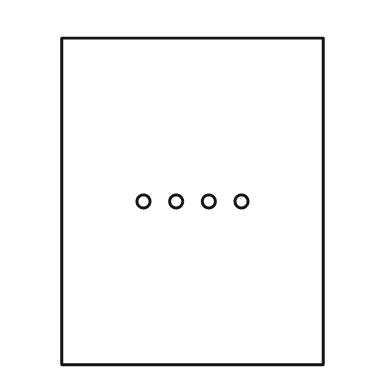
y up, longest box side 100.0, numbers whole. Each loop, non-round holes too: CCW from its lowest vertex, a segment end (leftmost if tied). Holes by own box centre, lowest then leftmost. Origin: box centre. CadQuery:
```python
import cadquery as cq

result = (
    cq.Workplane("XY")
    .moveTo(-40.0, -50.0)
    .lineTo(40.0, -50.0)
    .lineTo(40.0, 50.0)
    .lineTo(-40.0, 50.0)
    .close()
    .moveTo(-15.0, 0.0)
    .circle(2.0)
    .moveTo(-5.0, 0.0)
    .circle(2.0)
    .moveTo(5.0, 0.0)
    .circle(2.0)
    .moveTo(15.0, 0.0)
    .circle(2.0)
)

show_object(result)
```